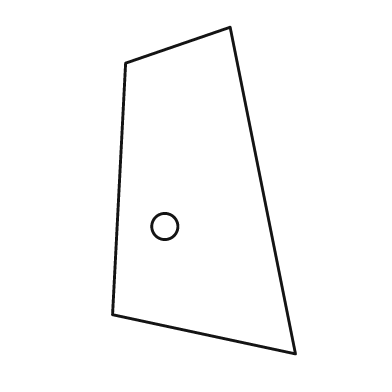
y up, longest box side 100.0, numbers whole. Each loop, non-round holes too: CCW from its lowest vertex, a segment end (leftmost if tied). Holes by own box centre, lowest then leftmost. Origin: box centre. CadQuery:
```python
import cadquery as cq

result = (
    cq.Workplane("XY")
    .moveTo(28.0, -50.0)
    .lineTo(8.0, 50.0)
    .lineTo(-24.0, 39.0)
    .lineTo(-28.0, -38.0)
    .close()
    .moveTo(-12.0, -11.0)
    .circle(4.0)
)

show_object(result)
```